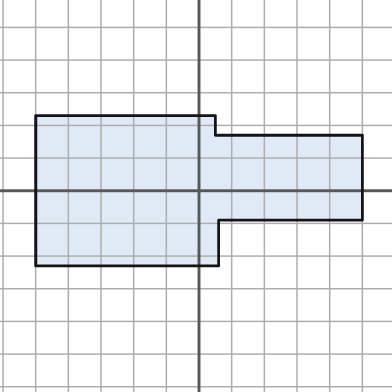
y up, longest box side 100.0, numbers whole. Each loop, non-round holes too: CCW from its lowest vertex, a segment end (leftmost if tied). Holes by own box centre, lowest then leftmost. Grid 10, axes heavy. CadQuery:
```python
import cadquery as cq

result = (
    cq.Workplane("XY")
    .moveTo(-50.0, -23.0)
    .lineTo(6.0, -23.0)
    .lineTo(6.0, -9.0)
    .lineTo(50.0, -9.0)
    .lineTo(50.0, 17.0)
    .lineTo(5.0, 17.0)
    .lineTo(5.0, 23.0)
    .lineTo(-50.0, 23.0)
    .close()
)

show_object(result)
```